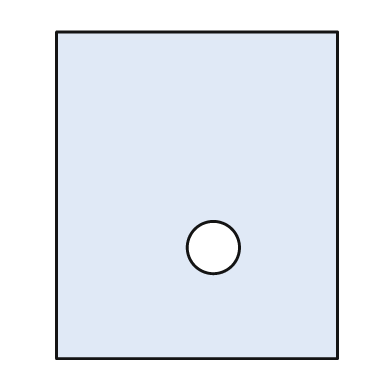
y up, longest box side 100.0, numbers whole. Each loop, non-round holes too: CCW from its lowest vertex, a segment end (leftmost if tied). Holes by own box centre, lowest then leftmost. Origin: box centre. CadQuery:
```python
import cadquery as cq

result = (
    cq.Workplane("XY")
    .moveTo(-43.0, -50.0)
    .lineTo(43.0, -50.0)
    .lineTo(43.0, 50.0)
    .lineTo(-43.0, 50.0)
    .close()
    .moveTo(5.0, -16.0)
    .circle(8.0)
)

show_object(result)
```